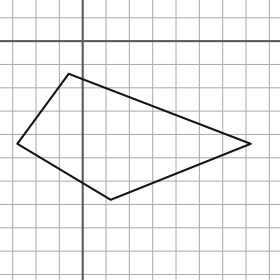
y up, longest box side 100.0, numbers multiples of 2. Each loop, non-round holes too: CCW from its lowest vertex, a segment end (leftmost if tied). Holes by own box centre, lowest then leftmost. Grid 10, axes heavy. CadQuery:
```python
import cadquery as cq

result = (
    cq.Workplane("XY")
    .moveTo(12.0, -68.0)
    .lineTo(72.0, -44.0)
    .lineTo(-6.0, -14.0)
    .lineTo(-28.0, -44.0)
    .close()
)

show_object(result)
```